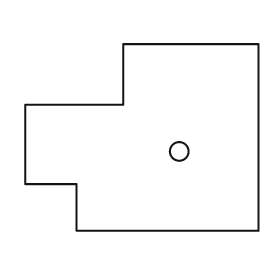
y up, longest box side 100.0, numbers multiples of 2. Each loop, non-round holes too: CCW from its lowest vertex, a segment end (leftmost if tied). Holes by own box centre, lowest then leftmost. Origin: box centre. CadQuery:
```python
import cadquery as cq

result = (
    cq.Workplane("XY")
    .moveTo(-28.0, -40.0)
    .lineTo(50.0, -40.0)
    .lineTo(50.0, 40.0)
    .lineTo(-8.0, 40.0)
    .lineTo(-8.0, 14.0)
    .lineTo(-50.0, 14.0)
    .lineTo(-50.0, -20.0)
    .lineTo(-28.0, -20.0)
    .close()
    .moveTo(16.0, -6.0)
    .circle(4.0)
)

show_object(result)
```